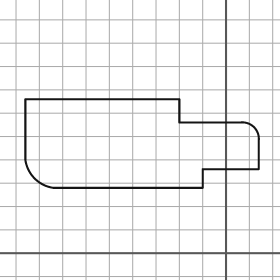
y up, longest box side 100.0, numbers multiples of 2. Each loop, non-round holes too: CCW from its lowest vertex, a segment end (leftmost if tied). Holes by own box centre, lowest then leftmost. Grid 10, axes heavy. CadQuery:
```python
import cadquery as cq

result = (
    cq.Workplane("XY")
    .moveTo(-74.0, 28.0)
    .lineTo(-10.0, 28.0)
    .lineTo(-10.0, 36.0)
    .lineTo(14.0, 36.0)
    .lineTo(14.0, 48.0)
    .threePointArc((12.0, 54.0), (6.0, 56.0))
    .lineTo(-20.0, 56.0)
    .lineTo(-20.0, 66.0)
    .lineTo(-86.0, 66.0)
    .lineTo(-86.0, 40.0)
    .threePointArc((-82.0, 32.0), (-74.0, 28.0))
    .close()
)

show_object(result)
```